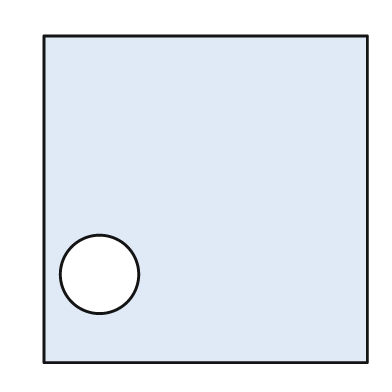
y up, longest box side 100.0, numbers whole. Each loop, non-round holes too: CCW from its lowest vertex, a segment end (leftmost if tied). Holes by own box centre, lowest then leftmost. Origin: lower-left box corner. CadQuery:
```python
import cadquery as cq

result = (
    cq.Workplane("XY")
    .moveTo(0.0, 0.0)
    .lineTo(99.0, 0.0)
    .lineTo(99.0, 100.0)
    .lineTo(0.0, 100.0)
    .close()
    .moveTo(17.0, 27.0)
    .circle(12.0)
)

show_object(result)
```